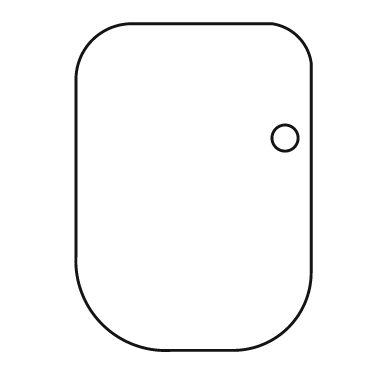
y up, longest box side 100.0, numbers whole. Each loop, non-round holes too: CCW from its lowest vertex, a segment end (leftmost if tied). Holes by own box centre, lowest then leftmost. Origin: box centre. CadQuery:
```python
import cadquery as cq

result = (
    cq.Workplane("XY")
    .moveTo(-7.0, -50.0)
    .lineTo(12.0, -50.0)
    .threePointArc((29.0, -43.0), (36.0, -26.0))
    .lineTo(36.0, 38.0)
    .threePointArc((32.0, 46.0), (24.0, 50.0))
    .lineTo(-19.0, 50.0)
    .threePointArc((-31.0, 45.0), (-36.0, 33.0))
    .lineTo(-36.0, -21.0)
    .threePointArc((-28.0, -42.0), (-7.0, -50.0))
    .close()
    .moveTo(28.0, 15.0)
    .circle(4.0)
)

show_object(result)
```